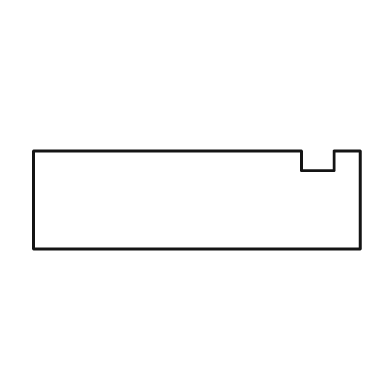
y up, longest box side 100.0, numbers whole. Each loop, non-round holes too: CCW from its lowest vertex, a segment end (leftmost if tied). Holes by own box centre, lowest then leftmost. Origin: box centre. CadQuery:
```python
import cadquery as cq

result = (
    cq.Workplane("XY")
    .moveTo(-50.0, -15.0)
    .lineTo(50.0, -15.0)
    .lineTo(50.0, 15.0)
    .lineTo(42.0, 15.0)
    .lineTo(42.0, 9.0)
    .lineTo(32.0, 9.0)
    .lineTo(32.0, 15.0)
    .lineTo(-50.0, 15.0)
    .close()
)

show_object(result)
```